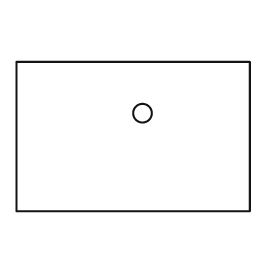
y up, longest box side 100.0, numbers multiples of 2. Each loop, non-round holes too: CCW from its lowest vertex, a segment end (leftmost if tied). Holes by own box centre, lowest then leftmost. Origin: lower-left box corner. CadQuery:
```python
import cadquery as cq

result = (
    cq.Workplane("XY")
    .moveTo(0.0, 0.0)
    .lineTo(100.0, 0.0)
    .lineTo(100.0, 64.0)
    .lineTo(0.0, 64.0)
    .close()
    .moveTo(54.0, 42.0)
    .circle(4.0)
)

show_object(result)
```